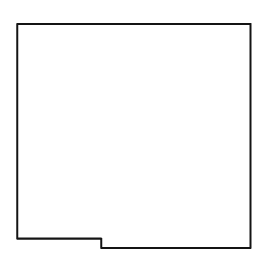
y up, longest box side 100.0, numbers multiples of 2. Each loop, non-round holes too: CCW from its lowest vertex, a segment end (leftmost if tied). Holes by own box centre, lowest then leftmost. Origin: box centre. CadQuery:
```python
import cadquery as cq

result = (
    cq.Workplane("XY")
    .moveTo(-14.0, -48.0)
    .lineTo(50.0, -48.0)
    .lineTo(50.0, 48.0)
    .lineTo(-50.0, 48.0)
    .lineTo(-50.0, -44.0)
    .lineTo(-14.0, -44.0)
    .close()
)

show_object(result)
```